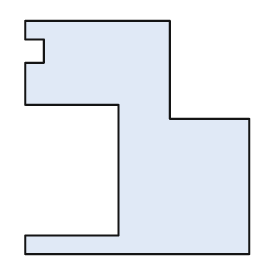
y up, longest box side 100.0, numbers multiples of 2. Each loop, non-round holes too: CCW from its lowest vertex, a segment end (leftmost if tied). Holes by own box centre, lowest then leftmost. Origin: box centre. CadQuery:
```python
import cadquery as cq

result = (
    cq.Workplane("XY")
    .moveTo(-48.0, -50.0)
    .lineTo(48.0, -50.0)
    .lineTo(48.0, 8.0)
    .lineTo(14.0, 8.0)
    .lineTo(14.0, 50.0)
    .lineTo(-48.0, 50.0)
    .lineTo(-48.0, 42.0)
    .lineTo(-40.0, 42.0)
    .lineTo(-40.0, 32.0)
    .lineTo(-48.0, 32.0)
    .lineTo(-48.0, 14.0)
    .lineTo(-8.0, 14.0)
    .lineTo(-8.0, -42.0)
    .lineTo(-48.0, -42.0)
    .close()
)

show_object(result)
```